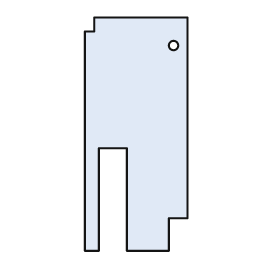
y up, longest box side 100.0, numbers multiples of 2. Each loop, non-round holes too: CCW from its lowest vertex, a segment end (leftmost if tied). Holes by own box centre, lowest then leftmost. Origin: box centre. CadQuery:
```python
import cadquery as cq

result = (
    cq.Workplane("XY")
    .moveTo(-22.0, -50.0)
    .lineTo(-16.0, -50.0)
    .lineTo(-16.0, -6.0)
    .lineTo(-4.0, -6.0)
    .lineTo(-4.0, -50.0)
    .lineTo(14.0, -50.0)
    .lineTo(14.0, -36.0)
    .lineTo(22.0, -36.0)
    .lineTo(22.0, 50.0)
    .lineTo(-18.0, 50.0)
    .lineTo(-18.0, 44.0)
    .lineTo(-22.0, 44.0)
    .close()
    .moveTo(16.0, 38.0)
    .circle(2.0)
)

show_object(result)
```